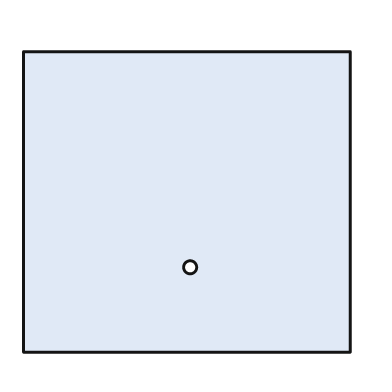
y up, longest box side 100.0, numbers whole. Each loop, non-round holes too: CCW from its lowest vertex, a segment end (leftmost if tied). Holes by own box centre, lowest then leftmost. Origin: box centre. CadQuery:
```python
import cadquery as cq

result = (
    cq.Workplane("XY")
    .moveTo(-50.0, -46.0)
    .lineTo(50.0, -46.0)
    .lineTo(50.0, 46.0)
    .lineTo(-50.0, 46.0)
    .close()
    .moveTo(1.0, -20.0)
    .circle(2.0)
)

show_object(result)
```